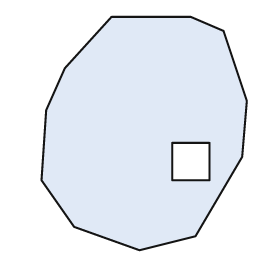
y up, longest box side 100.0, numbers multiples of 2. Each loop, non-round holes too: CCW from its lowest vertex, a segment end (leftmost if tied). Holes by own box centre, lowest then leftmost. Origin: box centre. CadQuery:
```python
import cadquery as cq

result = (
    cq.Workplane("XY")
    .moveTo(-2.0, -50.0)
    .lineTo(22.0, -44.0)
    .lineTo(42.0, -10.0)
    .lineTo(44.0, 14.0)
    .lineTo(34.0, 44.0)
    .lineTo(20.0, 50.0)
    .lineTo(-14.0, 50.0)
    .lineTo(-34.0, 28.0)
    .lineTo(-42.0, 10.0)
    .lineTo(-44.0, -20.0)
    .lineTo(-30.0, -40.0)
    .close()
    .moveTo(12.0, -20.0)
    .lineTo(28.0, -20.0)
    .lineTo(28.0, -4.0)
    .lineTo(12.0, -4.0)
    .close()
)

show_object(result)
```